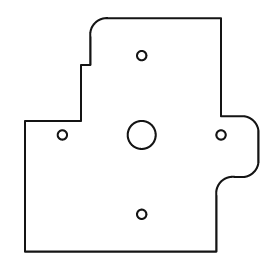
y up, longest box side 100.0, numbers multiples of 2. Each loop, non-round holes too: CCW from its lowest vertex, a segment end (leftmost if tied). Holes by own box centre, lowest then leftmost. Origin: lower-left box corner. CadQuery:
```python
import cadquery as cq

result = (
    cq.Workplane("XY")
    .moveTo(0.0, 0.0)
    .lineTo(82.0, 0.0)
    .lineTo(82.0, 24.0)
    .threePointArc((84.0, 30.0), (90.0, 32.0))
    .lineTo(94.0, 32.0)
    .threePointArc((98.0, 34.0), (100.0, 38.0))
    .lineTo(100.0, 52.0)
    .threePointArc((98.0, 56.0), (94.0, 58.0))
    .lineTo(84.0, 58.0)
    .lineTo(84.0, 100.0)
    .lineTo(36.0, 100.0)
    .threePointArc((30.0, 98.0), (28.0, 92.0))
    .lineTo(28.0, 80.0)
    .lineTo(24.0, 80.0)
    .lineTo(24.0, 56.0)
    .lineTo(0.0, 56.0)
    .close()
    .moveTo(50.0, 16.0)
    .circle(2.0)
    .moveTo(16.0, 50.0)
    .circle(2.0)
    .moveTo(50.0, 50.0)
    .circle(6.0)
    .moveTo(84.0, 50.0)
    .circle(2.0)
    .moveTo(50.0, 84.0)
    .circle(2.0)
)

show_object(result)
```